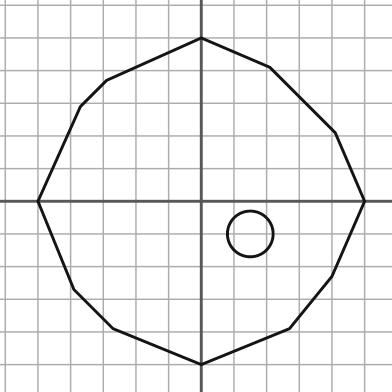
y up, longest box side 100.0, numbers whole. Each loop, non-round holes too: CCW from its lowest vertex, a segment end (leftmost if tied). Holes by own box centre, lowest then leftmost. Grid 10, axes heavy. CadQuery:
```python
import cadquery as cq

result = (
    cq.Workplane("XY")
    .moveTo(0.0, -50.0)
    .lineTo(27.0, -39.0)
    .lineTo(40.0, -23.0)
    .lineTo(50.0, 0.0)
    .lineTo(41.0, 21.0)
    .lineTo(21.0, 41.0)
    .lineTo(0.0, 50.0)
    .lineTo(-29.0, 37.0)
    .lineTo(-37.0, 29.0)
    .lineTo(-50.0, 0.0)
    .lineTo(-39.0, -27.0)
    .lineTo(-27.0, -39.0)
    .close()
    .moveTo(15.0, -10.0)
    .circle(7.0)
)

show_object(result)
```